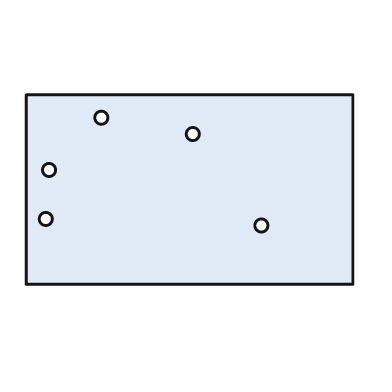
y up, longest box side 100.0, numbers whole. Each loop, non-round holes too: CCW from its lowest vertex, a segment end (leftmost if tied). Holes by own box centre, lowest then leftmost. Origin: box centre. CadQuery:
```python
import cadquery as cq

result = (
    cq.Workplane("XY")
    .moveTo(-50.0, -29.0)
    .lineTo(50.0, -29.0)
    .lineTo(50.0, 29.0)
    .lineTo(-50.0, 29.0)
    .close()
    .moveTo(22.0, -11.0)
    .circle(2.0)
    .moveTo(-44.0, -9.0)
    .circle(2.0)
    .moveTo(-43.0, 6.0)
    .circle(2.0)
    .moveTo(1.0, 17.0)
    .circle(2.0)
    .moveTo(-27.0, 22.0)
    .circle(2.0)
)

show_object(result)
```